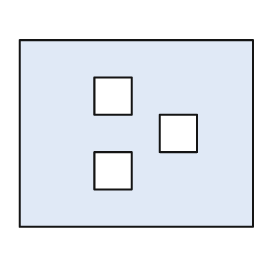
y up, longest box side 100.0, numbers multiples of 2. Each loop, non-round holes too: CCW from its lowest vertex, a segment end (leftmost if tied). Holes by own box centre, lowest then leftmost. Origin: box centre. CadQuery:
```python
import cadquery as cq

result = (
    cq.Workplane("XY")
    .moveTo(-50.0, -40.0)
    .lineTo(50.0, -40.0)
    .lineTo(50.0, 40.0)
    .lineTo(-50.0, 40.0)
    .close()
    .moveTo(-18.0, -24.0)
    .lineTo(-2.0, -24.0)
    .lineTo(-2.0, -8.0)
    .lineTo(-18.0, -8.0)
    .close()
    .moveTo(10.0, -8.0)
    .lineTo(26.0, -8.0)
    .lineTo(26.0, 8.0)
    .lineTo(10.0, 8.0)
    .close()
    .moveTo(-18.0, 8.0)
    .lineTo(-2.0, 8.0)
    .lineTo(-2.0, 24.0)
    .lineTo(-18.0, 24.0)
    .close()
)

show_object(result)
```